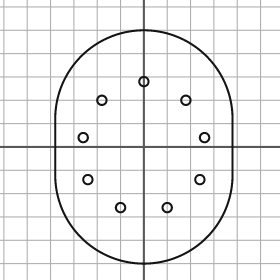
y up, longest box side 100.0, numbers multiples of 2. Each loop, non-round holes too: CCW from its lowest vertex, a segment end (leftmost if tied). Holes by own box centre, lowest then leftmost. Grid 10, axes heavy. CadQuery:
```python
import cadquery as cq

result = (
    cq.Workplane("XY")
    .moveTo(-38.0, -12.0)
    .threePointArc((0.0, -50.0), (38.0, -12.0))
    .lineTo(38.0, 12.0)
    .threePointArc((0.0, 50.0), (-38.0, 12.0))
    .close()
    .moveTo(-10.0, -26.0)
    .circle(2.0)
    .moveTo(10.0, -26.0)
    .circle(2.0)
    .moveTo(-24.0, -14.0)
    .circle(2.0)
    .moveTo(24.0, -14.0)
    .circle(2.0)
    .moveTo(-26.0, 4.0)
    .circle(2.0)
    .moveTo(26.0, 4.0)
    .circle(2.0)
    .moveTo(-18.0, 20.0)
    .circle(2.0)
    .moveTo(18.0, 20.0)
    .circle(2.0)
    .moveTo(0.0, 28.0)
    .circle(2.0)
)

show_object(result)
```